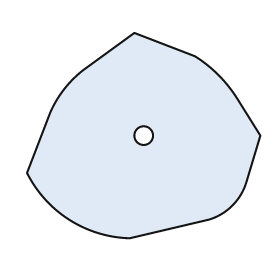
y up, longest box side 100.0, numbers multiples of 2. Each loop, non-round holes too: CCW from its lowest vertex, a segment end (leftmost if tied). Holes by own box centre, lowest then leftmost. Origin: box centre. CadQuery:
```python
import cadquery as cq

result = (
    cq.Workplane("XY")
    .moveTo(-6.0, -44.0)
    .lineTo(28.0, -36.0)
    .threePointArc((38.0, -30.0), (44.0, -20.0))
    .lineTo(50.0, 0.0)
    .lineTo(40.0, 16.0)
    .threePointArc((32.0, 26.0), (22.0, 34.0))
    .lineTo(-4.0, 44.0)
    .lineTo(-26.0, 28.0)
    .threePointArc((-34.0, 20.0), (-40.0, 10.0))
    .lineTo(-50.0, -16.0)
    .threePointArc((-32.0, -36.0), (-6.0, -44.0))
    .close()
    .moveTo(0.0, 0.0)
    .circle(4.0)
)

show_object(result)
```